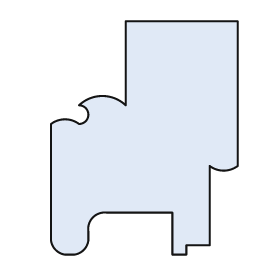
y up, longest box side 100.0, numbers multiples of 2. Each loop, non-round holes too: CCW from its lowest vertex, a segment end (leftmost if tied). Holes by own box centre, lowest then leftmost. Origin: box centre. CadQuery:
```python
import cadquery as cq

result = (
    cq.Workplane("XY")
    .moveTo(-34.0, -50.0)
    .lineTo(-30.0, -50.0)
    .threePointArc((-26.0, -48.0), (-24.0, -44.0))
    .lineTo(-24.0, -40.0)
    .threePointArc((-22.0, -34.0), (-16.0, -32.0))
    .lineTo(12.0, -32.0)
    .lineTo(12.0, -50.0)
    .lineTo(18.0, -50.0)
    .lineTo(18.0, -46.0)
    .lineTo(28.0, -46.0)
    .lineTo(28.0, -12.0)
    .threePointArc((34.0, -14.0), (40.0, -12.0))
    .lineTo(40.0, 50.0)
    .lineTo(-8.0, 50.0)
    .lineTo(-8.0, 14.0)
    .threePointArc((-18.0, 18.0), (-28.0, 14.0))
    .threePointArc((-24.0, 10.0), (-28.0, 6.0))
    .threePointArc((-34.0, 8.0), (-40.0, 6.0))
    .lineTo(-40.0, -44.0)
    .threePointArc((-38.0, -48.0), (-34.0, -50.0))
    .close()
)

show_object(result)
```